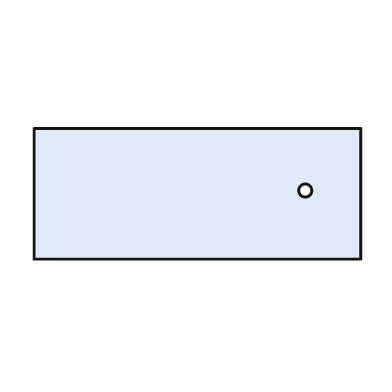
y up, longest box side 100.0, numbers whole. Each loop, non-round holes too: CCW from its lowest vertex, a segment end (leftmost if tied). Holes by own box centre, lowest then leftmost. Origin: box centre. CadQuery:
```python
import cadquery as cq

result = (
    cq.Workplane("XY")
    .moveTo(-50.0, -20.0)
    .lineTo(50.0, -20.0)
    .lineTo(50.0, 20.0)
    .lineTo(-50.0, 20.0)
    .close()
    .moveTo(33.0, 1.0)
    .circle(2.0)
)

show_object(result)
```